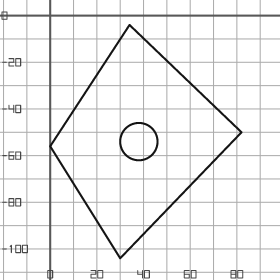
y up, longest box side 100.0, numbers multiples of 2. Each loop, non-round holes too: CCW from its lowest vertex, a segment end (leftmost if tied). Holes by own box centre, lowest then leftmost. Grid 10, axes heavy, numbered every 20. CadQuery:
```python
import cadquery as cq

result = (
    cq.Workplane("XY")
    .moveTo(30.0, -104.0)
    .lineTo(82.0, -50.0)
    .lineTo(34.0, -4.0)
    .lineTo(0.0, -56.0)
    .close()
    .moveTo(38.0, -54.0)
    .circle(8.0)
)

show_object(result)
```